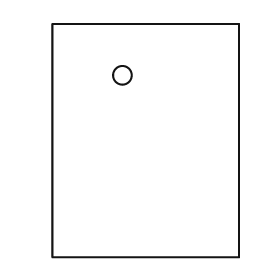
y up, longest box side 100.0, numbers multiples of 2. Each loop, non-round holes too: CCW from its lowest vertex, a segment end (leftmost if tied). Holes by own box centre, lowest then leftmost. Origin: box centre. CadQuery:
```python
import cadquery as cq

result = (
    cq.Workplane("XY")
    .moveTo(-40.0, -50.0)
    .lineTo(40.0, -50.0)
    .lineTo(40.0, 50.0)
    .lineTo(-40.0, 50.0)
    .close()
    .moveTo(-10.0, 28.0)
    .circle(4.0)
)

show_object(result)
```